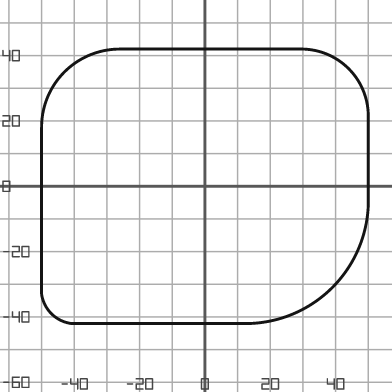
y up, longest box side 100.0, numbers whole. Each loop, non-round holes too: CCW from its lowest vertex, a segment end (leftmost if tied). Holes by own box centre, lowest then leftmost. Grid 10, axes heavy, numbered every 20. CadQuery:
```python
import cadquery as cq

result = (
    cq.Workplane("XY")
    .moveTo(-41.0, -42.0)
    .lineTo(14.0, -42.0)
    .threePointArc((39.0, -31.0), (50.0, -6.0))
    .lineTo(50.0, 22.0)
    .threePointArc((44.0, 36.0), (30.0, 42.0))
    .lineTo(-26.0, 42.0)
    .threePointArc((-43.0, 35.0), (-50.0, 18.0))
    .lineTo(-50.0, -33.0)
    .threePointArc((-47.0, -39.0), (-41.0, -42.0))
    .close()
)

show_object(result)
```